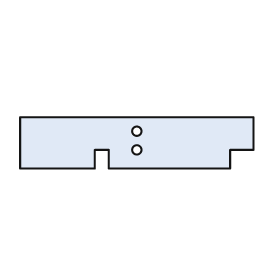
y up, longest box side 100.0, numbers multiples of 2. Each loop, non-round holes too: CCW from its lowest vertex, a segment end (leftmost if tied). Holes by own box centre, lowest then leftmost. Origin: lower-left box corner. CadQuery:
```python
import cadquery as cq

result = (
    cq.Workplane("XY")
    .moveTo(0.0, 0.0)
    .lineTo(32.0, 0.0)
    .lineTo(32.0, 8.0)
    .lineTo(38.0, 8.0)
    .lineTo(38.0, 0.0)
    .lineTo(90.0, 0.0)
    .lineTo(90.0, 8.0)
    .lineTo(100.0, 8.0)
    .lineTo(100.0, 22.0)
    .lineTo(0.0, 22.0)
    .close()
    .moveTo(50.0, 8.0)
    .circle(2.0)
    .moveTo(50.0, 16.0)
    .circle(2.0)
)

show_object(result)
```